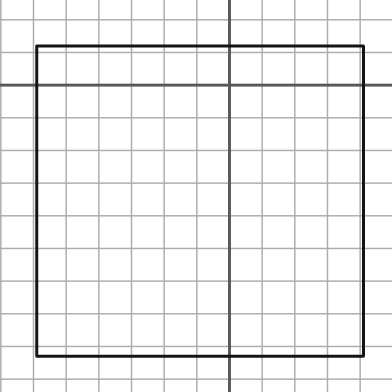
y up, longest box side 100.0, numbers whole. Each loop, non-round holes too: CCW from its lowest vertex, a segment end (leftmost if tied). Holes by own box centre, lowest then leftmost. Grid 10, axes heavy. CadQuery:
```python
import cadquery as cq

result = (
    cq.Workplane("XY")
    .moveTo(-59.0, -83.0)
    .lineTo(41.0, -83.0)
    .lineTo(41.0, 12.0)
    .lineTo(-59.0, 12.0)
    .close()
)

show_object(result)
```